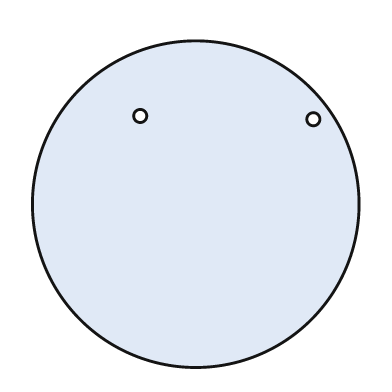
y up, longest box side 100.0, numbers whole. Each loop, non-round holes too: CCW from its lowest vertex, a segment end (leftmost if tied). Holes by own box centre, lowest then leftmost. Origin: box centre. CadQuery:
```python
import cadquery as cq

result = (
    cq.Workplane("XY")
    .moveTo(0.0, 0.0)
    .circle(50.0)
    .moveTo(36.0, 26.0)
    .circle(2.0)
    .moveTo(-17.0, 27.0)
    .circle(2.0)
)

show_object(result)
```